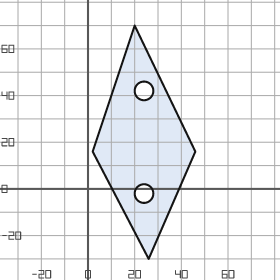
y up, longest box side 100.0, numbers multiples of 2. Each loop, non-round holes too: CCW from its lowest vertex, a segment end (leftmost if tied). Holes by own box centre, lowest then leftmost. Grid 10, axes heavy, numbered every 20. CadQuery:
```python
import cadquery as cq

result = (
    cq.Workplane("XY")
    .moveTo(26.0, -30.0)
    .lineTo(46.0, 16.0)
    .lineTo(20.0, 70.0)
    .lineTo(2.0, 16.0)
    .close()
    .moveTo(24.0, -2.0)
    .circle(4.0)
    .moveTo(24.0, 42.0)
    .circle(4.0)
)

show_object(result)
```